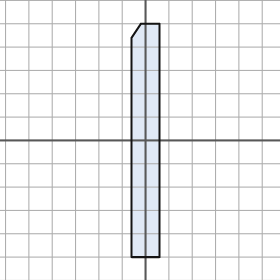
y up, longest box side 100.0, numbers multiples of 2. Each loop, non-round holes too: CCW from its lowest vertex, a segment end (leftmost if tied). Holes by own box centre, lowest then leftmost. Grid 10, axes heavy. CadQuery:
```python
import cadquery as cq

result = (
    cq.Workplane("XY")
    .moveTo(-6.0, -50.0)
    .lineTo(6.0, -50.0)
    .lineTo(6.0, 50.0)
    .lineTo(-2.0, 50.0)
    .lineTo(-6.0, 44.0)
    .close()
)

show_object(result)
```